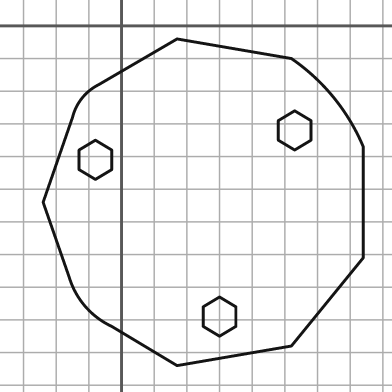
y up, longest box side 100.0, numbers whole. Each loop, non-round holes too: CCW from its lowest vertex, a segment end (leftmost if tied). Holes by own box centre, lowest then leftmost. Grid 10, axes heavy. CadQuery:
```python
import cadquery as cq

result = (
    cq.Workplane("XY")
    .moveTo(17.0, -104.0)
    .lineTo(52.0, -98.0)
    .lineTo(74.0, -71.0)
    .lineTo(74.0, -37.0)
    .threePointArc((65.0, -22.0), (52.0, -10.0))
    .lineTo(17.0, -4.0)
    .lineTo(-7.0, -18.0)
    .threePointArc((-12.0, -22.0), (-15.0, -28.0))
    .lineTo(-24.0, -54.0)
    .lineTo(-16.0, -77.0)
    .threePointArc((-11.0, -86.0), (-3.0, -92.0))
    .close()
    .moveTo(30.0, -95.0)
    .lineTo(35.0, -92.0)
    .lineTo(35.0, -86.0)
    .lineTo(30.0, -83.0)
    .lineTo(25.0, -86.0)
    .lineTo(25.0, -92.0)
    .close()
    .moveTo(-8.0, -47.0)
    .lineTo(-3.0, -44.0)
    .lineTo(-3.0, -38.0)
    .lineTo(-8.0, -35.0)
    .lineTo(-13.0, -38.0)
    .lineTo(-13.0, -44.0)
    .close()
    .moveTo(53.0, -38.0)
    .lineTo(58.0, -35.0)
    .lineTo(58.0, -29.0)
    .lineTo(53.0, -26.0)
    .lineTo(48.0, -29.0)
    .lineTo(48.0, -35.0)
    .close()
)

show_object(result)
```